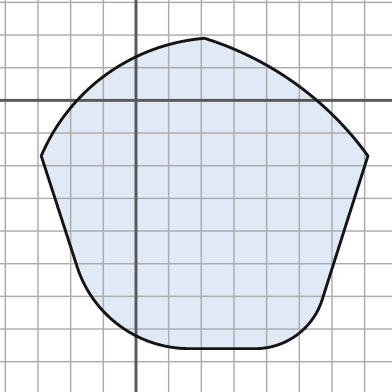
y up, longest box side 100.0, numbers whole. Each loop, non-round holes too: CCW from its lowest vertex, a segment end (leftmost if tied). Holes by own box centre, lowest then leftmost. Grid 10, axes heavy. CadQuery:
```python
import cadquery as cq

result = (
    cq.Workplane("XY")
    .moveTo(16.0, -76.0)
    .lineTo(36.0, -76.0)
    .threePointArc((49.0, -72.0), (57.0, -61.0))
    .lineTo(71.0, -17.0)
    .threePointArc((49.0, 5.0), (21.0, 19.0))
    .threePointArc((-9.0, 8.0), (-29.0, -17.0))
    .lineTo(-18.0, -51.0)
    .threePointArc((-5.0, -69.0), (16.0, -76.0))
    .close()
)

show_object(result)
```